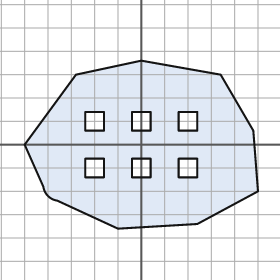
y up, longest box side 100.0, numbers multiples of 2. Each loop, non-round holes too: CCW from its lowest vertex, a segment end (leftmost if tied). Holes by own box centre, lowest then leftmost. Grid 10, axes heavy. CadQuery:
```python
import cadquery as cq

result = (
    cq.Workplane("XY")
    .moveTo(-10.0, -36.0)
    .lineTo(24.0, -34.0)
    .lineTo(50.0, -20.0)
    .lineTo(48.0, 6.0)
    .lineTo(34.0, 30.0)
    .lineTo(0.0, 36.0)
    .lineTo(-28.0, 30.0)
    .lineTo(-50.0, 0.0)
    .lineTo(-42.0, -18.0)
    .threePointArc((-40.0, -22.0), (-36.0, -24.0))
    .close()
    .moveTo(-24.0, -14.0)
    .lineTo(-16.0, -14.0)
    .lineTo(-16.0, -6.0)
    .lineTo(-24.0, -6.0)
    .close()
    .moveTo(-4.0, -14.0)
    .lineTo(4.0, -14.0)
    .lineTo(4.0, -6.0)
    .lineTo(-4.0, -6.0)
    .close()
    .moveTo(16.0, -14.0)
    .lineTo(24.0, -14.0)
    .lineTo(24.0, -6.0)
    .lineTo(16.0, -6.0)
    .close()
    .moveTo(-24.0, 6.0)
    .lineTo(-16.0, 6.0)
    .lineTo(-16.0, 14.0)
    .lineTo(-24.0, 14.0)
    .close()
    .moveTo(-4.0, 6.0)
    .lineTo(4.0, 6.0)
    .lineTo(4.0, 14.0)
    .lineTo(-4.0, 14.0)
    .close()
    .moveTo(16.0, 6.0)
    .lineTo(24.0, 6.0)
    .lineTo(24.0, 14.0)
    .lineTo(16.0, 14.0)
    .close()
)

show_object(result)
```